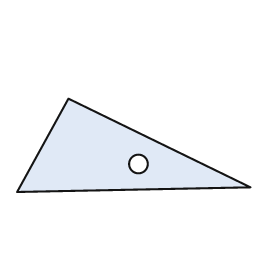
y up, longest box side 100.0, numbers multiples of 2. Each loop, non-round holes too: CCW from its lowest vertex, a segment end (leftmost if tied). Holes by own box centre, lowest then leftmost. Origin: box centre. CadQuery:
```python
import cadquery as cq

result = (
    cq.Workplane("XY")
    .moveTo(-50.0, -20.0)
    .lineTo(50.0, -18.0)
    .lineTo(-28.0, 20.0)
    .close()
    .moveTo(2.0, -8.0)
    .circle(4.0)
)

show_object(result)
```